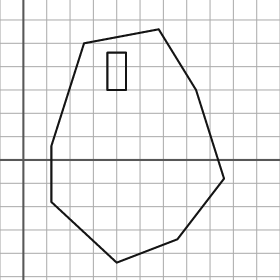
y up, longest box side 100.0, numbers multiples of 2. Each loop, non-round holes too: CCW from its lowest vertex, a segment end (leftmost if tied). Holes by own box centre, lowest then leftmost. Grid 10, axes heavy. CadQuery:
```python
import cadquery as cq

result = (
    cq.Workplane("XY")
    .moveTo(40.0, -44.0)
    .lineTo(66.0, -34.0)
    .lineTo(86.0, -8.0)
    .lineTo(74.0, 30.0)
    .lineTo(58.0, 56.0)
    .lineTo(26.0, 50.0)
    .lineTo(12.0, 6.0)
    .lineTo(12.0, -18.0)
    .close()
    .moveTo(36.0, 30.0)
    .lineTo(44.0, 30.0)
    .lineTo(44.0, 46.0)
    .lineTo(36.0, 46.0)
    .close()
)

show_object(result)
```